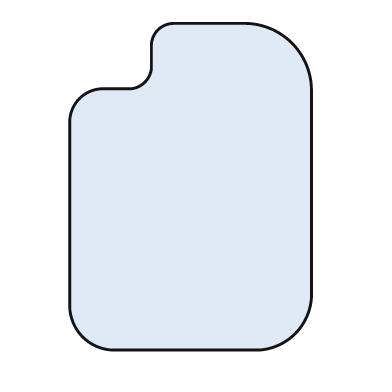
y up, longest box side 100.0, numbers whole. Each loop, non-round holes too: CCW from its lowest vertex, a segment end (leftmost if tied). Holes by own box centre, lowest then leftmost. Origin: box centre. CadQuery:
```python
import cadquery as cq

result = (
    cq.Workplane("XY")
    .moveTo(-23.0, -50.0)
    .lineTo(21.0, -50.0)
    .threePointArc((32.0, -45.0), (37.0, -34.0))
    .lineTo(37.0, 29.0)
    .threePointArc((31.0, 44.0), (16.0, 50.0))
    .lineTo(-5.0, 50.0)
    .threePointArc((-10.0, 48.0), (-12.0, 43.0))
    .lineTo(-12.0, 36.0)
    .threePointArc((-14.0, 32.0), (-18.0, 30.0))
    .lineTo(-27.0, 30.0)
    .threePointArc((-34.0, 27.0), (-37.0, 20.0))
    .lineTo(-37.0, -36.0)
    .threePointArc((-33.0, -46.0), (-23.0, -50.0))
    .close()
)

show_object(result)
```